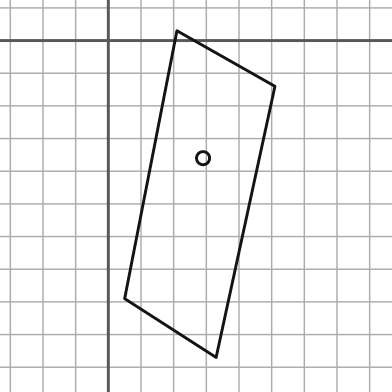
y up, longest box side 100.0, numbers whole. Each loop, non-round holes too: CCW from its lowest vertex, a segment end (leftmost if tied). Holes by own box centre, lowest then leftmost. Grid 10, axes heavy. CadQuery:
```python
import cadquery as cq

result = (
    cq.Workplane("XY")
    .moveTo(33.0, -97.0)
    .lineTo(51.0, -14.0)
    .lineTo(21.0, 3.0)
    .lineTo(5.0, -79.0)
    .close()
    .moveTo(29.0, -36.0)
    .circle(2.0)
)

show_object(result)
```